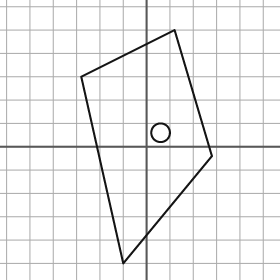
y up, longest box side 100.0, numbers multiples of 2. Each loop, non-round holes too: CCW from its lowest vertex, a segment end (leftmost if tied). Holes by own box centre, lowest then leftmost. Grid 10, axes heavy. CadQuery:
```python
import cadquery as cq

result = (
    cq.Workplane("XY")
    .moveTo(-10.0, -50.0)
    .lineTo(28.0, -4.0)
    .lineTo(12.0, 50.0)
    .lineTo(-28.0, 30.0)
    .close()
    .moveTo(6.0, 6.0)
    .circle(4.0)
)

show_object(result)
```